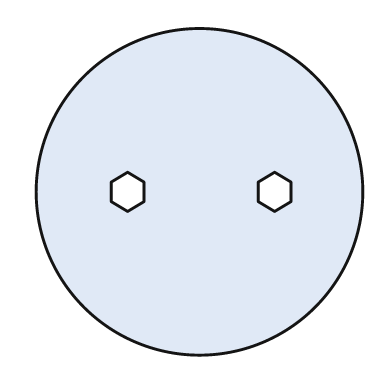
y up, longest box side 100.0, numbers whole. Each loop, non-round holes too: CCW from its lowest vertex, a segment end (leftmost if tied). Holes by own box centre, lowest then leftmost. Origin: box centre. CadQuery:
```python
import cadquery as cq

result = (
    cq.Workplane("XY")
    .moveTo(0.0, 0.0)
    .circle(50.0)
    .moveTo(-22.0, -6.0)
    .lineTo(-17.0, -3.0)
    .lineTo(-17.0, 3.0)
    .lineTo(-22.0, 6.0)
    .lineTo(-27.0, 3.0)
    .lineTo(-27.0, -3.0)
    .close()
    .moveTo(23.0, -6.0)
    .lineTo(28.0, -3.0)
    .lineTo(28.0, 3.0)
    .lineTo(23.0, 6.0)
    .lineTo(18.0, 3.0)
    .lineTo(18.0, -3.0)
    .close()
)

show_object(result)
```